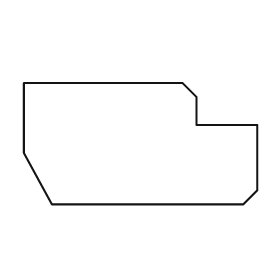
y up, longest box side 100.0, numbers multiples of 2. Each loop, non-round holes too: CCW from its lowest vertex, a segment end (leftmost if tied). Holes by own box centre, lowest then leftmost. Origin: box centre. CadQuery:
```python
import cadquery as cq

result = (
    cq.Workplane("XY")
    .moveTo(-38.0, -26.0)
    .lineTo(44.0, -26.0)
    .lineTo(50.0, -20.0)
    .lineTo(50.0, 8.0)
    .lineTo(24.0, 8.0)
    .lineTo(24.0, 20.0)
    .lineTo(18.0, 26.0)
    .lineTo(-50.0, 26.0)
    .lineTo(-50.0, -4.0)
    .close()
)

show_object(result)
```